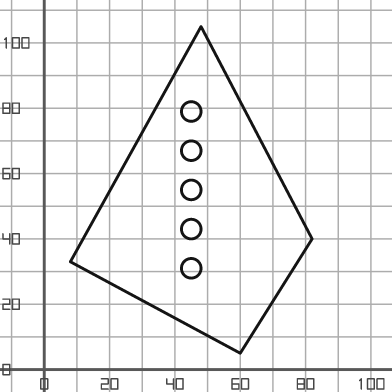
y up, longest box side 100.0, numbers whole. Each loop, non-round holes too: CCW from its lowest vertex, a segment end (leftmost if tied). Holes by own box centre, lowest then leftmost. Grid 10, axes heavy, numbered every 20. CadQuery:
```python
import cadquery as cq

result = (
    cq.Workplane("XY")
    .moveTo(60.0, 5.0)
    .lineTo(82.0, 40.0)
    .lineTo(48.0, 105.0)
    .lineTo(8.0, 33.0)
    .close()
    .moveTo(45.0, 31.0)
    .circle(3.0)
    .moveTo(45.0, 43.0)
    .circle(3.0)
    .moveTo(45.0, 55.0)
    .circle(3.0)
    .moveTo(45.0, 67.0)
    .circle(3.0)
    .moveTo(45.0, 79.0)
    .circle(3.0)
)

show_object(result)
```